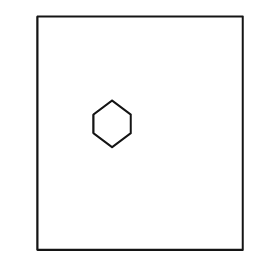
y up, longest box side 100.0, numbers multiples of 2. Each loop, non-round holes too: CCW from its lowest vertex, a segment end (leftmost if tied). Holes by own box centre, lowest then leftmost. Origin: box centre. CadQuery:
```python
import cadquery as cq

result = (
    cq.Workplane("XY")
    .moveTo(-44.0, -50.0)
    .lineTo(44.0, -50.0)
    .lineTo(44.0, 50.0)
    .lineTo(-44.0, 50.0)
    .close()
    .moveTo(-12.0, -6.0)
    .lineTo(-4.0, 0.0)
    .lineTo(-4.0, 8.0)
    .lineTo(-12.0, 14.0)
    .lineTo(-20.0, 8.0)
    .lineTo(-20.0, 0.0)
    .close()
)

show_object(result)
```